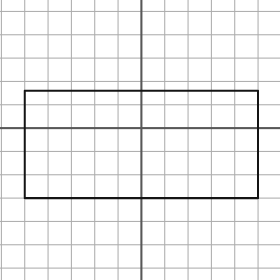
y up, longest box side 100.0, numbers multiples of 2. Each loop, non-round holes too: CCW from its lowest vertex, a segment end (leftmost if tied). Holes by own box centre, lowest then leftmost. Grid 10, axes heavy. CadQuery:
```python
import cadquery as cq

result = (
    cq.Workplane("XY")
    .moveTo(-50.0, -30.0)
    .lineTo(50.0, -30.0)
    .lineTo(50.0, 16.0)
    .lineTo(-50.0, 16.0)
    .close()
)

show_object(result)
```